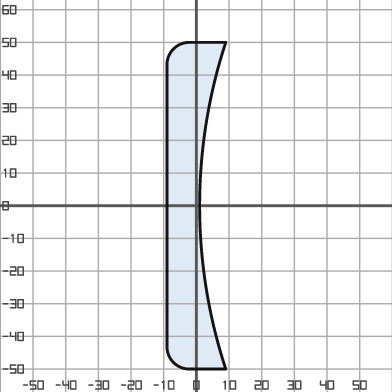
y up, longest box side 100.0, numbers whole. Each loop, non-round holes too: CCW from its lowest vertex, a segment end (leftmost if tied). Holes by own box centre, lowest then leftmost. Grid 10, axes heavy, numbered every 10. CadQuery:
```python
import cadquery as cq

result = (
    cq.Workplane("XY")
    .moveTo(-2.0, -50.0)
    .lineTo(9.0, -50.0)
    .threePointArc((1.0, 0.0), (9.0, 50.0))
    .lineTo(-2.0, 50.0)
    .threePointArc((-7.0, 48.0), (-9.0, 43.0))
    .lineTo(-9.0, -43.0)
    .threePointArc((-7.0, -48.0), (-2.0, -50.0))
    .close()
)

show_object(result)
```